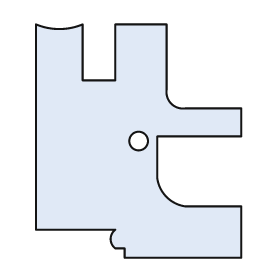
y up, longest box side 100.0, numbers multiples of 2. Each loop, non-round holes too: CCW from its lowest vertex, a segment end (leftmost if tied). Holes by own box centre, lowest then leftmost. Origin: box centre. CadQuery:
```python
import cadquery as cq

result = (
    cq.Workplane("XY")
    .moveTo(-6.0, -50.0)
    .lineTo(44.0, -50.0)
    .lineTo(44.0, -28.0)
    .lineTo(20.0, -28.0)
    .threePointArc((12.0, -24.0), (8.0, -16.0))
    .lineTo(8.0, 2.0)
    .lineTo(44.0, 2.0)
    .lineTo(44.0, 14.0)
    .lineTo(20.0, 14.0)
    .threePointArc((14.0, 16.0), (12.0, 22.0))
    .lineTo(12.0, 50.0)
    .lineTo(-10.0, 50.0)
    .lineTo(-10.0, 26.0)
    .lineTo(-24.0, 26.0)
    .lineTo(-24.0, 50.0)
    .threePointArc((-34.0, 48.0), (-44.0, 50.0))
    .lineTo(-44.0, -38.0)
    .lineTo(-10.0, -38.0)
    .threePointArc((-12.0, -42.0), (-10.0, -46.0))
    .lineTo(-6.0, -46.0)
    .close()
    .moveTo(0.0, 0.0)
    .circle(4.0)
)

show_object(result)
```